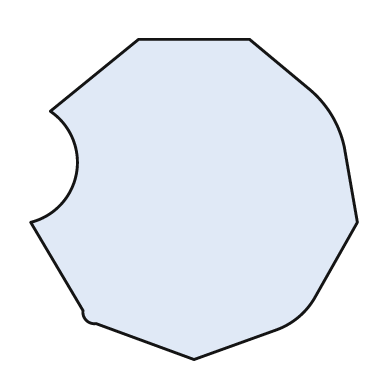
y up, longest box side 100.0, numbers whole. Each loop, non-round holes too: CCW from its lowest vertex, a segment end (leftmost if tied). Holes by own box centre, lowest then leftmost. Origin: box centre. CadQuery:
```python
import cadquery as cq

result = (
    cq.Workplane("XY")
    .moveTo(0.0, -49.0)
    .lineTo(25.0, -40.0)
    .threePointArc((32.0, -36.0), (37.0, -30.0))
    .lineTo(50.0, -7.0)
    .lineTo(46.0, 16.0)
    .threePointArc((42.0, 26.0), (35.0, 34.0))
    .lineTo(17.0, 49.0)
    .lineTo(-17.0, 49.0)
    .lineTo(-44.0, 27.0)
    .threePointArc((-36.0, 8.0), (-50.0, -7.0))
    .lineTo(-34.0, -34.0)
    .threePointArc((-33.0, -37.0), (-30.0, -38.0))
    .close()
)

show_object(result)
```